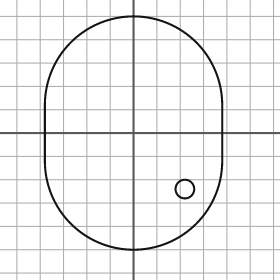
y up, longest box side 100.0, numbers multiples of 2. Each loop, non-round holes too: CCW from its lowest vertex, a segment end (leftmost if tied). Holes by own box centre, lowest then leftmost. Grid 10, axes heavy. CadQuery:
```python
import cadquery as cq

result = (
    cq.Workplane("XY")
    .moveTo(-38.0, -12.0)
    .threePointArc((0.0, -50.0), (38.0, -12.0))
    .lineTo(38.0, 12.0)
    .threePointArc((0.0, 50.0), (-38.0, 12.0))
    .close()
    .moveTo(22.0, -24.0)
    .circle(4.0)
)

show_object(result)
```